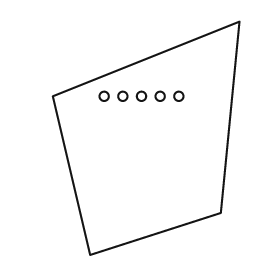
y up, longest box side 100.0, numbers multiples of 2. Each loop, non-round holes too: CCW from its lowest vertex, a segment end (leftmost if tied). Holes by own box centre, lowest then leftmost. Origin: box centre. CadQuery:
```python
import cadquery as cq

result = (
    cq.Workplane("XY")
    .moveTo(-24.0, -50.0)
    .lineTo(32.0, -32.0)
    .lineTo(40.0, 50.0)
    .lineTo(-40.0, 18.0)
    .close()
    .moveTo(-18.0, 18.0)
    .circle(2.0)
    .moveTo(-10.0, 18.0)
    .circle(2.0)
    .moveTo(-2.0, 18.0)
    .circle(2.0)
    .moveTo(6.0, 18.0)
    .circle(2.0)
    .moveTo(14.0, 18.0)
    .circle(2.0)
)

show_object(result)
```